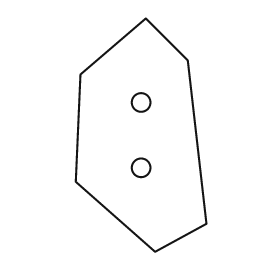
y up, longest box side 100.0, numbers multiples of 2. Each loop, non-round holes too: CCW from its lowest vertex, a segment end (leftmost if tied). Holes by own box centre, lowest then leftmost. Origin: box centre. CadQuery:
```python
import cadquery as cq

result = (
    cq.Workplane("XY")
    .moveTo(6.0, -50.0)
    .lineTo(28.0, -38.0)
    .lineTo(20.0, 32.0)
    .lineTo(2.0, 50.0)
    .lineTo(-26.0, 26.0)
    .lineTo(-28.0, -20.0)
    .close()
    .moveTo(0.0, -14.0)
    .circle(4.0)
    .moveTo(0.0, 14.0)
    .circle(4.0)
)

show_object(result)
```